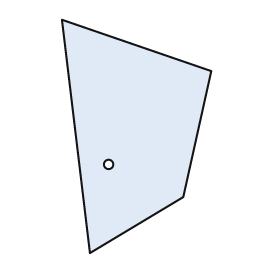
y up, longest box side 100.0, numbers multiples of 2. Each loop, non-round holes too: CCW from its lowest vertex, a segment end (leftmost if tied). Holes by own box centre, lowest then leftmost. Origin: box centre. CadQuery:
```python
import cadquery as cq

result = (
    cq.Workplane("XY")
    .moveTo(-20.0, -50.0)
    .lineTo(20.0, -26.0)
    .lineTo(32.0, 28.0)
    .lineTo(-32.0, 50.0)
    .close()
    .moveTo(-12.0, -12.0)
    .circle(2.0)
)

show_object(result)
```